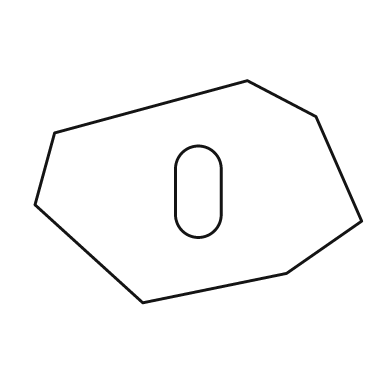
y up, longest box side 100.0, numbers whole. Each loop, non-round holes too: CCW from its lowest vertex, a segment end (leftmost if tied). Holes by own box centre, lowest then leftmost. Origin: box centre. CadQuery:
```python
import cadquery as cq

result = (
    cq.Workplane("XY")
    .moveTo(-17.0, -34.0)
    .lineTo(27.0, -25.0)
    .lineTo(50.0, -9.0)
    .lineTo(36.0, 23.0)
    .lineTo(15.0, 34.0)
    .lineTo(-44.0, 18.0)
    .lineTo(-50.0, -4.0)
    .close()
    .moveTo(-7.0, -7.0)
    .threePointArc((0.0, -14.0), (7.0, -7.0))
    .lineTo(7.0, 7.0)
    .threePointArc((0.0, 14.0), (-7.0, 7.0))
    .close()
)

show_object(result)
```